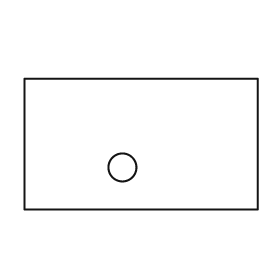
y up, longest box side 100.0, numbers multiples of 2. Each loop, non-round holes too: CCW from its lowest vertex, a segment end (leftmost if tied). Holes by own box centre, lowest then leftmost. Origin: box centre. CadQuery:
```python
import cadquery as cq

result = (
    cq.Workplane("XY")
    .moveTo(-50.0, -28.0)
    .lineTo(50.0, -28.0)
    .lineTo(50.0, 28.0)
    .lineTo(-50.0, 28.0)
    .close()
    .moveTo(-8.0, -10.0)
    .circle(6.0)
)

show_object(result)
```